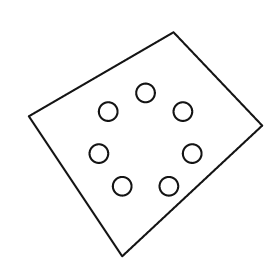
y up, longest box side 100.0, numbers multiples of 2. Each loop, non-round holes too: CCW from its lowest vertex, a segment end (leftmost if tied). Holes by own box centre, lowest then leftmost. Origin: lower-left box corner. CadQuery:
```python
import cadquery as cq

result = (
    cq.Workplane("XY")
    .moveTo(40.0, 0.0)
    .lineTo(100.0, 56.0)
    .lineTo(62.0, 96.0)
    .lineTo(0.0, 60.0)
    .close()
    .moveTo(40.0, 30.0)
    .circle(4.0)
    .moveTo(60.0, 30.0)
    .circle(4.0)
    .moveTo(30.0, 44.0)
    .circle(4.0)
    .moveTo(70.0, 44.0)
    .circle(4.0)
    .moveTo(34.0, 62.0)
    .circle(4.0)
    .moveTo(66.0, 62.0)
    .circle(4.0)
    .moveTo(50.0, 70.0)
    .circle(4.0)
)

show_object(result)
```